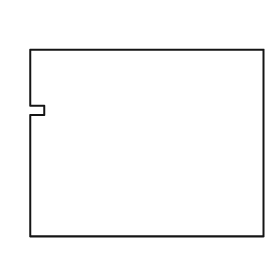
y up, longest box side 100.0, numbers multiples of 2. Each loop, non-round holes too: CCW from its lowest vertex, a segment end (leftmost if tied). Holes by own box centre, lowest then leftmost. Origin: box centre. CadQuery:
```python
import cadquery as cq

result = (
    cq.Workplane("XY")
    .moveTo(-50.0, -40.0)
    .lineTo(50.0, -40.0)
    .lineTo(50.0, 40.0)
    .lineTo(-50.0, 40.0)
    .lineTo(-50.0, 16.0)
    .lineTo(-44.0, 16.0)
    .lineTo(-44.0, 12.0)
    .lineTo(-50.0, 12.0)
    .close()
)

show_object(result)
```